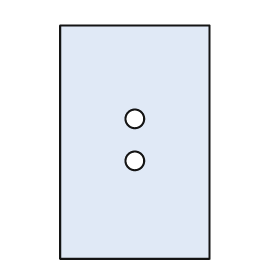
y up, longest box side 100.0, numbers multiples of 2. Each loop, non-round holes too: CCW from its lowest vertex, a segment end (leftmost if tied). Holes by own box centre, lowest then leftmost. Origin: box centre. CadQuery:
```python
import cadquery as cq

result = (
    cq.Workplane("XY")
    .moveTo(-32.0, -50.0)
    .lineTo(32.0, -50.0)
    .lineTo(32.0, 50.0)
    .lineTo(-32.0, 50.0)
    .close()
    .moveTo(0.0, -8.0)
    .circle(4.0)
    .moveTo(0.0, 10.0)
    .circle(4.0)
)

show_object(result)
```